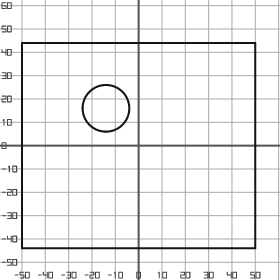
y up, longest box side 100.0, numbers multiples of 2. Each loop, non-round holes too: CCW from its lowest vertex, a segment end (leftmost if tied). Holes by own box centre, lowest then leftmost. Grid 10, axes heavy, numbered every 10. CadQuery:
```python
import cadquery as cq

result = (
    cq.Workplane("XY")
    .moveTo(-50.0, -44.0)
    .lineTo(50.0, -44.0)
    .lineTo(50.0, 44.0)
    .lineTo(-50.0, 44.0)
    .close()
    .moveTo(-14.0, 16.0)
    .circle(10.0)
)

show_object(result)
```